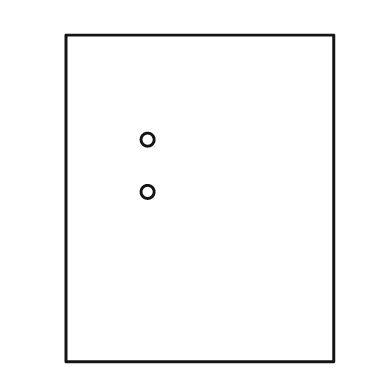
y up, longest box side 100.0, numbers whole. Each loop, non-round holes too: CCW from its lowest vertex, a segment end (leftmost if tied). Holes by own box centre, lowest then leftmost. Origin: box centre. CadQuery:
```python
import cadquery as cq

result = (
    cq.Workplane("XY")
    .moveTo(-41.0, -50.0)
    .lineTo(41.0, -50.0)
    .lineTo(41.0, 50.0)
    .lineTo(-41.0, 50.0)
    .close()
    .moveTo(-16.0, 2.0)
    .circle(2.0)
    .moveTo(-16.0, 18.0)
    .circle(2.0)
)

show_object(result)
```